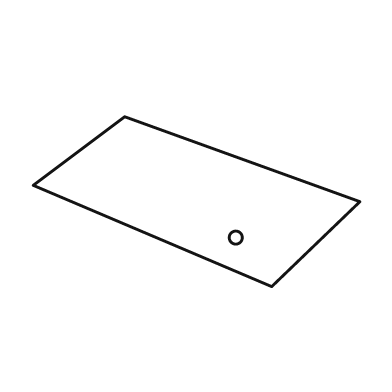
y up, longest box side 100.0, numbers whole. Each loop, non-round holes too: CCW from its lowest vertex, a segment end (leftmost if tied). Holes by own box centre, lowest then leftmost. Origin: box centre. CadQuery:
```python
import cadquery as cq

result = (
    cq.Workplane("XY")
    .moveTo(23.0, -26.0)
    .lineTo(50.0, 0.0)
    .lineTo(-22.0, 26.0)
    .lineTo(-50.0, 5.0)
    .close()
    .moveTo(12.0, -11.0)
    .circle(2.0)
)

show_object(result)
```